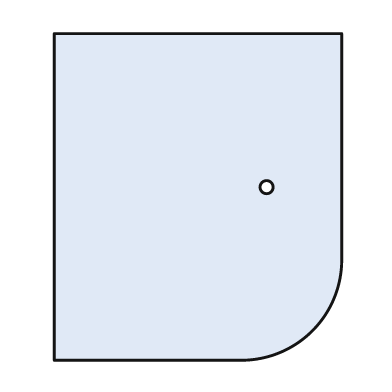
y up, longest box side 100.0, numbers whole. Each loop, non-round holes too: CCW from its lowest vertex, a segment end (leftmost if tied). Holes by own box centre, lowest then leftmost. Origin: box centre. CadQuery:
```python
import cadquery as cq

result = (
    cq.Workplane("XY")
    .moveTo(-44.0, -50.0)
    .lineTo(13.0, -50.0)
    .threePointArc((35.0, -41.0), (44.0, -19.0))
    .lineTo(44.0, 50.0)
    .lineTo(-44.0, 50.0)
    .close()
    .moveTo(21.0, 3.0)
    .circle(2.0)
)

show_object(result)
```